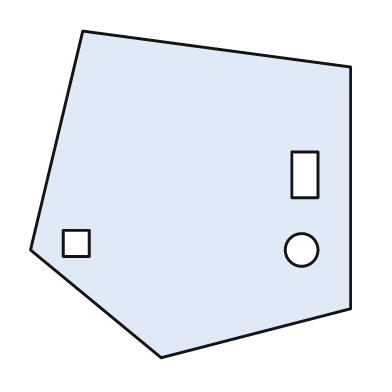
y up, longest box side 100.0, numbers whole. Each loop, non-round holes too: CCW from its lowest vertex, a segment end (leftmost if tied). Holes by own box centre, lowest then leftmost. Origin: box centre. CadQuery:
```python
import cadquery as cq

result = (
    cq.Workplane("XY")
    .moveTo(-9.0, -50.0)
    .lineTo(49.0, -35.0)
    .lineTo(49.0, 39.0)
    .lineTo(-33.0, 50.0)
    .lineTo(-49.0, -17.0)
    .close()
    .moveTo(34.0, -17.0)
    .circle(5.0)
    .moveTo(-39.0, -19.0)
    .lineTo(-31.0, -19.0)
    .lineTo(-31.0, -11.0)
    .lineTo(-39.0, -11.0)
    .close()
    .moveTo(31.0, -1.0)
    .lineTo(39.0, -1.0)
    .lineTo(39.0, 13.0)
    .lineTo(31.0, 13.0)
    .close()
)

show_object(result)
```